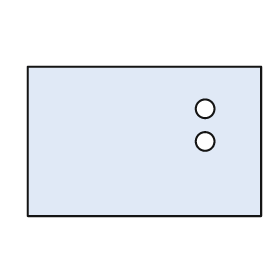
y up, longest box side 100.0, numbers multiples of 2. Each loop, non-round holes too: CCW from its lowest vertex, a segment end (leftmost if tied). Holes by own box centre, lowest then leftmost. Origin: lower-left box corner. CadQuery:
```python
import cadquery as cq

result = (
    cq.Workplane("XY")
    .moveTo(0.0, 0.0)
    .lineTo(100.0, 0.0)
    .lineTo(100.0, 64.0)
    .lineTo(0.0, 64.0)
    .close()
    .moveTo(76.0, 32.0)
    .circle(4.0)
    .moveTo(76.0, 46.0)
    .circle(4.0)
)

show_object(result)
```